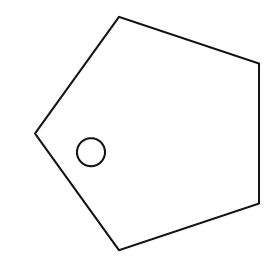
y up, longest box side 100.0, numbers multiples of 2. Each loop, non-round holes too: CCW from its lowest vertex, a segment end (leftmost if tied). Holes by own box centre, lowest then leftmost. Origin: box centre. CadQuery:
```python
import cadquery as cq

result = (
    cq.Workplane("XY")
    .moveTo(-12.0, -50.0)
    .lineTo(48.0, -30.0)
    .lineTo(48.0, 30.0)
    .lineTo(-12.0, 50.0)
    .lineTo(-48.0, 0.0)
    .close()
    .moveTo(-24.0, -8.0)
    .circle(6.0)
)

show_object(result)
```